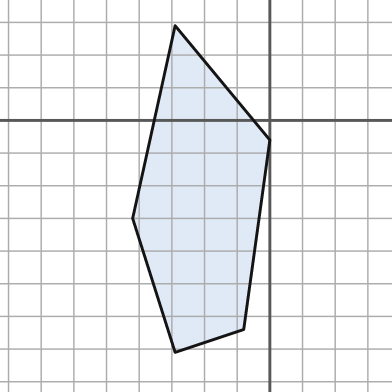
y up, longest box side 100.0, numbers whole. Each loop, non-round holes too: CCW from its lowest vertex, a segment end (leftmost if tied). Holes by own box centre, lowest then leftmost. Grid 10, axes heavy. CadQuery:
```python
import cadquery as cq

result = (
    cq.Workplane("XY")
    .moveTo(-29.0, -71.0)
    .lineTo(-8.0, -64.0)
    .lineTo(0.0, -6.0)
    .lineTo(-29.0, 29.0)
    .lineTo(-42.0, -30.0)
    .close()
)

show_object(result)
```